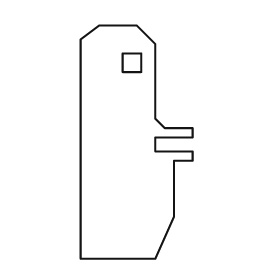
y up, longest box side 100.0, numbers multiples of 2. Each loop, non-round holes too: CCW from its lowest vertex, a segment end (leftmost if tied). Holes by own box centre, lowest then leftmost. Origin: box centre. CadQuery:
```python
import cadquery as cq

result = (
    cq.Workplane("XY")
    .moveTo(-24.0, -50.0)
    .lineTo(8.0, -50.0)
    .lineTo(16.0, -32.0)
    .lineTo(16.0, -8.0)
    .lineTo(24.0, -8.0)
    .lineTo(24.0, -4.0)
    .lineTo(8.0, -4.0)
    .lineTo(8.0, 2.0)
    .lineTo(24.0, 2.0)
    .lineTo(24.0, 6.0)
    .lineTo(12.0, 6.0)
    .lineTo(8.0, 10.0)
    .lineTo(8.0, 42.0)
    .lineTo(0.0, 50.0)
    .lineTo(-16.0, 50.0)
    .lineTo(-24.0, 44.0)
    .close()
    .moveTo(-6.0, 30.0)
    .lineTo(2.0, 30.0)
    .lineTo(2.0, 38.0)
    .lineTo(-6.0, 38.0)
    .close()
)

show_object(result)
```